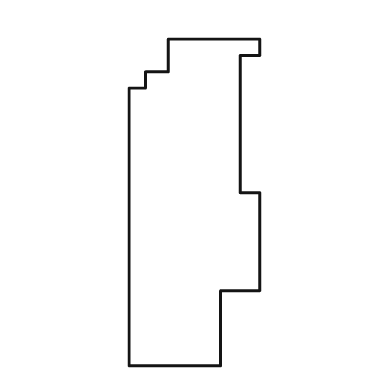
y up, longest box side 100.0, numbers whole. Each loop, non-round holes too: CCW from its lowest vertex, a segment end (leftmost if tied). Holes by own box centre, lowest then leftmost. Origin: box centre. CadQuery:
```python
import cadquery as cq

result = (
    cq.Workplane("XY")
    .moveTo(-20.0, -50.0)
    .lineTo(8.0, -50.0)
    .lineTo(8.0, -27.0)
    .lineTo(20.0, -27.0)
    .lineTo(20.0, 3.0)
    .lineTo(14.0, 3.0)
    .lineTo(14.0, 45.0)
    .lineTo(20.0, 45.0)
    .lineTo(20.0, 50.0)
    .lineTo(-8.0, 50.0)
    .lineTo(-8.0, 40.0)
    .lineTo(-15.0, 40.0)
    .lineTo(-15.0, 35.0)
    .lineTo(-20.0, 35.0)
    .close()
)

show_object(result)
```